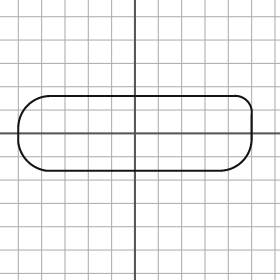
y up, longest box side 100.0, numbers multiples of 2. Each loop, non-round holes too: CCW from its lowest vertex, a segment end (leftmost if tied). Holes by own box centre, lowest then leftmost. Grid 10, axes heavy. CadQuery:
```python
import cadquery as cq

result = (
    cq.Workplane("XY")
    .moveTo(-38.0, -16.0)
    .lineTo(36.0, -16.0)
    .threePointArc((46.0, -12.0), (50.0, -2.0))
    .lineTo(50.0, 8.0)
    .threePointArc((48.0, 14.0), (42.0, 16.0))
    .lineTo(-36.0, 16.0)
    .threePointArc((-46.0, 12.0), (-50.0, 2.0))
    .lineTo(-50.0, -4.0)
    .threePointArc((-46.0, -12.0), (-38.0, -16.0))
    .close()
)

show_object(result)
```